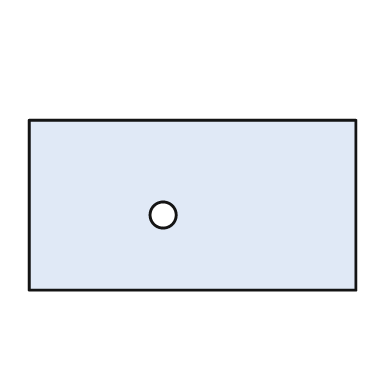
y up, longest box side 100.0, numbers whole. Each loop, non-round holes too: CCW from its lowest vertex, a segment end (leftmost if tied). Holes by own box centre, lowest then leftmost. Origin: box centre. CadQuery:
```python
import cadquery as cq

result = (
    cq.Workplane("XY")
    .moveTo(-50.0, -26.0)
    .lineTo(50.0, -26.0)
    .lineTo(50.0, 26.0)
    .lineTo(-50.0, 26.0)
    .close()
    .moveTo(-9.0, -3.0)
    .circle(4.0)
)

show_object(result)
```